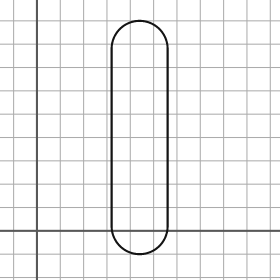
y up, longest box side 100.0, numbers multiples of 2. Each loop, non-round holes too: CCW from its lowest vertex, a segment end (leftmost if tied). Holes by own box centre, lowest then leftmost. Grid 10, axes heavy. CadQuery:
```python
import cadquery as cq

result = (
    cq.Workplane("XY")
    .moveTo(32.0, 2.0)
    .threePointArc((44.0, -10.0), (56.0, 2.0))
    .lineTo(56.0, 78.0)
    .threePointArc((44.0, 90.0), (32.0, 78.0))
    .close()
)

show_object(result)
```